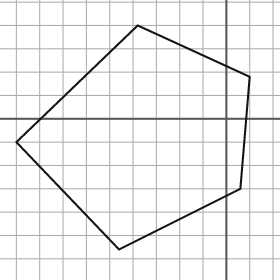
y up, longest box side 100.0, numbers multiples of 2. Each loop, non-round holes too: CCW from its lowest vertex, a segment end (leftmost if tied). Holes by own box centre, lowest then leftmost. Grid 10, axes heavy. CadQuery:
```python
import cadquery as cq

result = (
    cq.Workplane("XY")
    .moveTo(-46.0, -56.0)
    .lineTo(6.0, -30.0)
    .lineTo(10.0, 18.0)
    .lineTo(-38.0, 40.0)
    .lineTo(-90.0, -10.0)
    .close()
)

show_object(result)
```